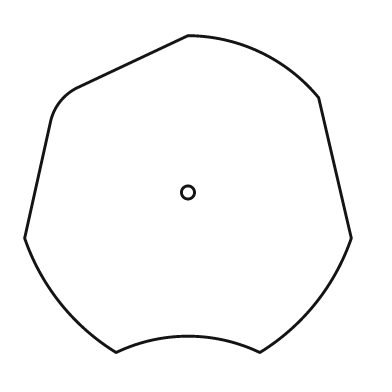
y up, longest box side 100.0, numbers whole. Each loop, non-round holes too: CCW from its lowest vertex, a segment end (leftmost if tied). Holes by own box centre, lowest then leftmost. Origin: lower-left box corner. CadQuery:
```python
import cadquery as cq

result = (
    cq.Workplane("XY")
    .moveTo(28.0, 0.0)
    .threePointArc((50.0, 5.0), (72.0, 0.0))
    .threePointArc((89.0, 15.0), (100.0, 35.0))
    .lineTo(90.0, 78.0)
    .threePointArc((72.0, 92.0), (50.0, 97.0))
    .lineTo(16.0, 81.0)
    .threePointArc((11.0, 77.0), (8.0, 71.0))
    .lineTo(0.0, 35.0)
    .threePointArc((11.0, 15.0), (28.0, 0.0))
    .close()
    .moveTo(50.0, 49.0)
    .circle(2.0)
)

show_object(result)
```